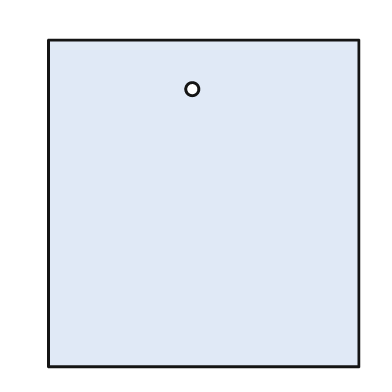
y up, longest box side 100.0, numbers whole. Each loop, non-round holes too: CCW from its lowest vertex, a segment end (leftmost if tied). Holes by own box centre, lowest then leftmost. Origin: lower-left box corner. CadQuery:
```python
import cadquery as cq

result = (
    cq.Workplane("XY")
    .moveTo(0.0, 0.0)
    .lineTo(95.0, 0.0)
    .lineTo(95.0, 100.0)
    .lineTo(0.0, 100.0)
    .close()
    .moveTo(44.0, 85.0)
    .circle(2.0)
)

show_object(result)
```